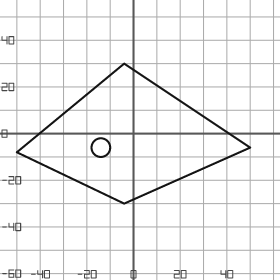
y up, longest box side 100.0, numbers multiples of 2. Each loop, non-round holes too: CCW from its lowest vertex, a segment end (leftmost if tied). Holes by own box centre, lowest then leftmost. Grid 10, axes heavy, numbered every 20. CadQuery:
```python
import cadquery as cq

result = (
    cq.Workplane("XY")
    .moveTo(-4.0, -30.0)
    .lineTo(50.0, -6.0)
    .lineTo(-4.0, 30.0)
    .lineTo(-50.0, -8.0)
    .close()
    .moveTo(-14.0, -6.0)
    .circle(4.0)
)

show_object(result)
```